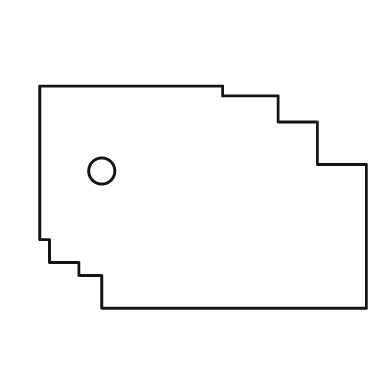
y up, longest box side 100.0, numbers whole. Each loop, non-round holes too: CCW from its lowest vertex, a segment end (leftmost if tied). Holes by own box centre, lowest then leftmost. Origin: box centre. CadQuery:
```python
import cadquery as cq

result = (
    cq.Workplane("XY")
    .moveTo(-31.0, -34.0)
    .lineTo(50.0, -34.0)
    .lineTo(50.0, 10.0)
    .lineTo(35.0, 10.0)
    .lineTo(35.0, 23.0)
    .lineTo(23.0, 23.0)
    .lineTo(23.0, 31.0)
    .lineTo(6.0, 31.0)
    .lineTo(6.0, 34.0)
    .lineTo(-50.0, 34.0)
    .lineTo(-50.0, -13.0)
    .lineTo(-47.0, -13.0)
    .lineTo(-47.0, -20.0)
    .lineTo(-38.0, -20.0)
    .lineTo(-38.0, -24.0)
    .lineTo(-31.0, -24.0)
    .close()
    .moveTo(-31.0, 8.0)
    .circle(4.0)
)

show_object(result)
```